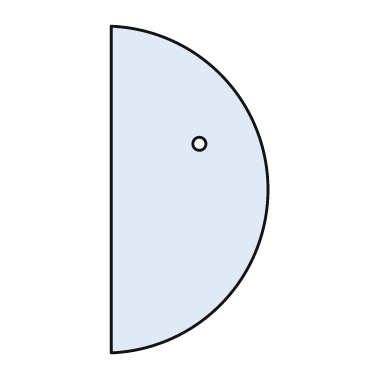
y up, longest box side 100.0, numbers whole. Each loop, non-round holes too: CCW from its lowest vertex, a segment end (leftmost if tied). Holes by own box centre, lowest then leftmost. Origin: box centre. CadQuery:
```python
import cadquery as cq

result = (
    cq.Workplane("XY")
    .moveTo(-24.0, -50.0)
    .threePointArc((24.0, 0.0), (-24.0, 50.0))
    .close()
    .moveTo(3.0, 14.0)
    .circle(2.0)
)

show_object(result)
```